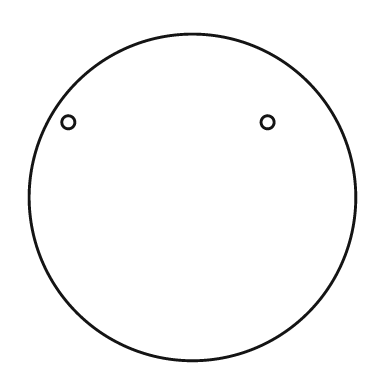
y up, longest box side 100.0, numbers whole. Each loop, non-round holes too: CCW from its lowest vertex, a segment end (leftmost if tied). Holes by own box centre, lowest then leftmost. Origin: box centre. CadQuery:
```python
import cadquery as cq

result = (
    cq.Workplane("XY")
    .moveTo(0.0, 0.0)
    .circle(50.0)
    .moveTo(-38.0, 23.0)
    .circle(2.0)
    .moveTo(23.0, 23.0)
    .circle(2.0)
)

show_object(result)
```